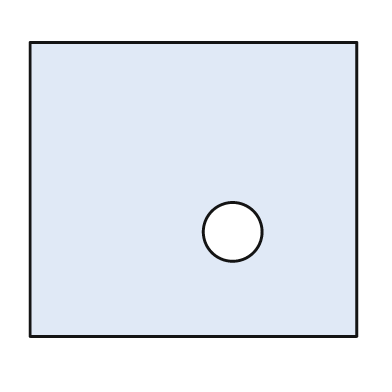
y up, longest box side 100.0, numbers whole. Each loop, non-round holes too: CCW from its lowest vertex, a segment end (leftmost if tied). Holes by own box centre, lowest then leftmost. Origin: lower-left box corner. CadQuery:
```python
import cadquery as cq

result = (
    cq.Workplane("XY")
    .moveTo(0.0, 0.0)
    .lineTo(100.0, 0.0)
    .lineTo(100.0, 90.0)
    .lineTo(0.0, 90.0)
    .close()
    .moveTo(62.0, 32.0)
    .circle(9.0)
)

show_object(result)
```